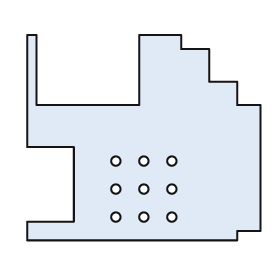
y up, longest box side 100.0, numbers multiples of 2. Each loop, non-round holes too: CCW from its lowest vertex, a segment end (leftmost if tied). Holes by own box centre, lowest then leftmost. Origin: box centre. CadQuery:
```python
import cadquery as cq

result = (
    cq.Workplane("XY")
    .moveTo(-50.0, -44.0)
    .lineTo(40.0, -44.0)
    .lineTo(40.0, -40.0)
    .lineTo(50.0, -40.0)
    .lineTo(50.0, 14.0)
    .lineTo(40.0, 14.0)
    .lineTo(40.0, 24.0)
    .lineTo(28.0, 24.0)
    .lineTo(28.0, 38.0)
    .lineTo(16.0, 38.0)
    .lineTo(16.0, 44.0)
    .lineTo(-2.0, 44.0)
    .lineTo(-2.0, 14.0)
    .lineTo(-46.0, 14.0)
    .lineTo(-46.0, 44.0)
    .lineTo(-50.0, 44.0)
    .lineTo(-50.0, -4.0)
    .lineTo(-30.0, -4.0)
    .lineTo(-30.0, -36.0)
    .lineTo(-50.0, -36.0)
    .close()
    .moveTo(-12.0, -34.0)
    .circle(2.0)
    .moveTo(0.0, -34.0)
    .circle(2.0)
    .moveTo(12.0, -34.0)
    .circle(2.0)
    .moveTo(-12.0, -22.0)
    .circle(2.0)
    .moveTo(0.0, -22.0)
    .circle(2.0)
    .moveTo(12.0, -22.0)
    .circle(2.0)
    .moveTo(-12.0, -10.0)
    .circle(2.0)
    .moveTo(0.0, -10.0)
    .circle(2.0)
    .moveTo(12.0, -10.0)
    .circle(2.0)
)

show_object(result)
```